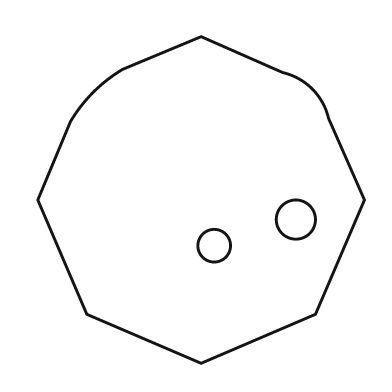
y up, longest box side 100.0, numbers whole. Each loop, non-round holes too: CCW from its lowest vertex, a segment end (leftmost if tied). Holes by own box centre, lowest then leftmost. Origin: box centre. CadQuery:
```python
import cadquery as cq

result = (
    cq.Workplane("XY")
    .moveTo(0.0, -50.0)
    .lineTo(35.0, -35.0)
    .lineTo(50.0, 0.0)
    .lineTo(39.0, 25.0)
    .threePointArc((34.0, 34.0), (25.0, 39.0))
    .lineTo(0.0, 50.0)
    .lineTo(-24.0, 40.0)
    .threePointArc((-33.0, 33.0), (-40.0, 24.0))
    .lineTo(-50.0, 0.0)
    .lineTo(-35.0, -35.0)
    .close()
    .moveTo(4.0, -14.0)
    .circle(5.0)
    .moveTo(29.0, -6.0)
    .circle(6.0)
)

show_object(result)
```